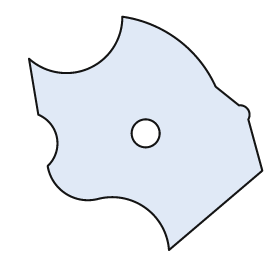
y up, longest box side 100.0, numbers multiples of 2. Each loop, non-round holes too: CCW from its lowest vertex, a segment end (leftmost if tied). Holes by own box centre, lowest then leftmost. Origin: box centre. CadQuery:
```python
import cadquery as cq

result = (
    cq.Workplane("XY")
    .moveTo(10.0, -50.0)
    .lineTo(50.0, -16.0)
    .lineTo(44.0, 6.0)
    .threePointArc((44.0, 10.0), (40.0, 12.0))
    .lineTo(30.0, 20.0)
    .threePointArc((14.0, 40.0), (-10.0, 50.0))
    .threePointArc((-24.0, 28.0), (-50.0, 32.0))
    .lineTo(-46.0, 8.0)
    .threePointArc((-38.0, -2.0), (-42.0, -14.0))
    .threePointArc((-34.0, -26.0), (-20.0, -28.0))
    .threePointArc((0.0, -32.0), (10.0, -50.0))
    .close()
    .moveTo(0.0, 0.0)
    .circle(6.0)
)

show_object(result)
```